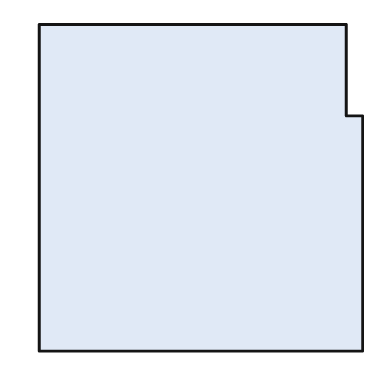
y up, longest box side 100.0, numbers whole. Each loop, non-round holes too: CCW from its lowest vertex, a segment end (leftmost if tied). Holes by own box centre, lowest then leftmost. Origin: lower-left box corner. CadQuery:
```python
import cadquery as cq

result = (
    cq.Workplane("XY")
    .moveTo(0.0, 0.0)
    .lineTo(99.0, 0.0)
    .lineTo(99.0, 72.0)
    .lineTo(94.0, 72.0)
    .lineTo(94.0, 100.0)
    .lineTo(0.0, 100.0)
    .close()
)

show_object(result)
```